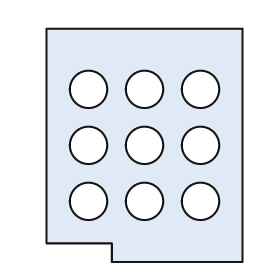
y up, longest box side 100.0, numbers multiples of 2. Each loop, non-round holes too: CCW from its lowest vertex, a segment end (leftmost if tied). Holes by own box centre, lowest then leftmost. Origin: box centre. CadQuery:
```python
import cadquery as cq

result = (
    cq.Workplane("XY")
    .moveTo(-14.0, -50.0)
    .lineTo(42.0, -50.0)
    .lineTo(42.0, 50.0)
    .lineTo(-42.0, 50.0)
    .lineTo(-42.0, -42.0)
    .lineTo(-14.0, -42.0)
    .close()
    .moveTo(-24.0, -24.0)
    .circle(8.0)
    .moveTo(0.0, -24.0)
    .circle(8.0)
    .moveTo(24.0, -24.0)
    .circle(8.0)
    .moveTo(-24.0, 0.0)
    .circle(8.0)
    .moveTo(0.0, 0.0)
    .circle(8.0)
    .moveTo(24.0, 0.0)
    .circle(8.0)
    .moveTo(-24.0, 24.0)
    .circle(8.0)
    .moveTo(0.0, 24.0)
    .circle(8.0)
    .moveTo(24.0, 24.0)
    .circle(8.0)
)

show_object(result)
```